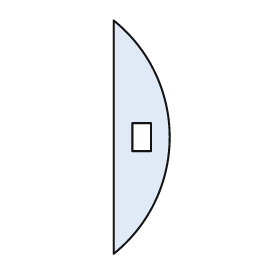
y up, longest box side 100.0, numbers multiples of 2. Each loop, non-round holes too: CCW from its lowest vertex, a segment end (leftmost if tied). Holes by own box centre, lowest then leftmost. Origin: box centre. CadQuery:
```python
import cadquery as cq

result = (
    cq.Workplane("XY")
    .moveTo(-12.0, -50.0)
    .threePointArc((12.0, 0.0), (-12.0, 50.0))
    .close()
    .moveTo(-4.0, -6.0)
    .lineTo(4.0, -6.0)
    .lineTo(4.0, 6.0)
    .lineTo(-4.0, 6.0)
    .close()
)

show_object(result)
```